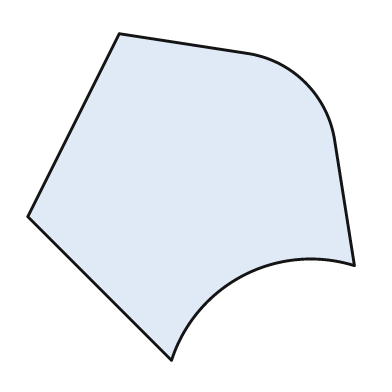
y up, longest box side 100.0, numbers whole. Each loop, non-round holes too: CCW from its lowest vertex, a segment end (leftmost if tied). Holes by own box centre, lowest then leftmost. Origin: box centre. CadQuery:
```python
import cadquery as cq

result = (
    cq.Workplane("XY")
    .moveTo(-6.0, -50.0)
    .threePointArc((16.0, -24.0), (50.0, -21.0))
    .lineTo(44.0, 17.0)
    .threePointArc((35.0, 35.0), (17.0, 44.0))
    .lineTo(-22.0, 50.0)
    .lineTo(-50.0, -6.0)
    .close()
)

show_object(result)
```